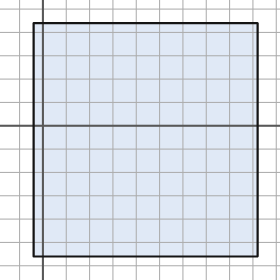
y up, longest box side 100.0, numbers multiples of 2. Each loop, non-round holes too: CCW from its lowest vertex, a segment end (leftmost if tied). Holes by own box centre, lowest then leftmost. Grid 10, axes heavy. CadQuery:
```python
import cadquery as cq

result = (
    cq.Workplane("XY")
    .moveTo(-4.0, -56.0)
    .lineTo(92.0, -56.0)
    .lineTo(92.0, 44.0)
    .lineTo(-4.0, 44.0)
    .close()
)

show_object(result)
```